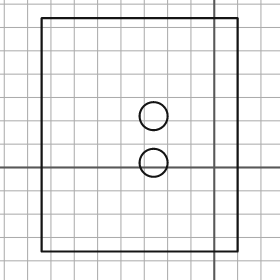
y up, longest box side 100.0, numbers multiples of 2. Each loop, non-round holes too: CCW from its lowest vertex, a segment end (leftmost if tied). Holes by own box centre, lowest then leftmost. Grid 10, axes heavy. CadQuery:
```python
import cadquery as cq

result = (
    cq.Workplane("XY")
    .moveTo(-74.0, -36.0)
    .lineTo(10.0, -36.0)
    .lineTo(10.0, 64.0)
    .lineTo(-74.0, 64.0)
    .close()
    .moveTo(-26.0, 2.0)
    .circle(6.0)
    .moveTo(-26.0, 22.0)
    .circle(6.0)
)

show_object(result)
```